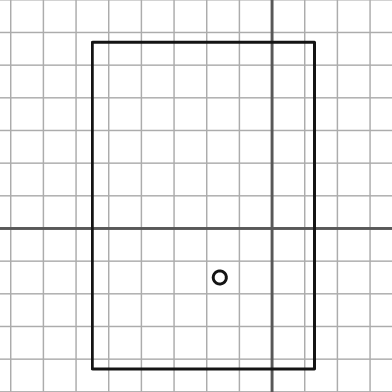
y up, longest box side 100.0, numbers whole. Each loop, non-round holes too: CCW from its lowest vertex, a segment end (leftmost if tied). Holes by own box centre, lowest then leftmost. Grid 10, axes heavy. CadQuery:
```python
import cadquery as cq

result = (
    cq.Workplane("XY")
    .moveTo(-55.0, -43.0)
    .lineTo(13.0, -43.0)
    .lineTo(13.0, 57.0)
    .lineTo(-55.0, 57.0)
    .close()
    .moveTo(-16.0, -15.0)
    .circle(2.0)
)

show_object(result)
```